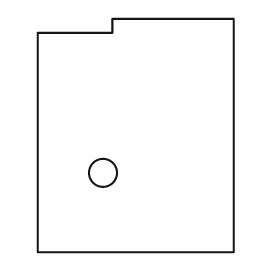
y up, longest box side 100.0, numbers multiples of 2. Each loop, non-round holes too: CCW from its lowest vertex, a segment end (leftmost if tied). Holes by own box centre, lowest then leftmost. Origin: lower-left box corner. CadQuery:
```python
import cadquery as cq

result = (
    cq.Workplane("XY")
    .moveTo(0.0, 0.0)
    .lineTo(84.0, 0.0)
    .lineTo(84.0, 100.0)
    .lineTo(32.0, 100.0)
    .lineTo(32.0, 94.0)
    .lineTo(0.0, 94.0)
    .close()
    .moveTo(28.0, 34.0)
    .circle(6.0)
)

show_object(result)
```